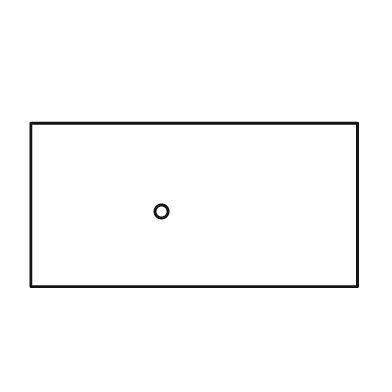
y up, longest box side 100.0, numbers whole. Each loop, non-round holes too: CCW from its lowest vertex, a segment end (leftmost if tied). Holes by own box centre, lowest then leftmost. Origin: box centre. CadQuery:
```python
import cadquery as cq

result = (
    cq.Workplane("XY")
    .moveTo(-50.0, -25.0)
    .lineTo(50.0, -25.0)
    .lineTo(50.0, 25.0)
    .lineTo(-50.0, 25.0)
    .close()
    .moveTo(-10.0, -2.0)
    .circle(2.0)
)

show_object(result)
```